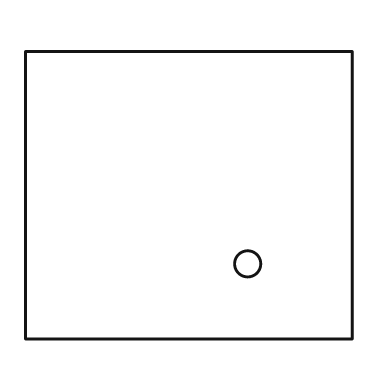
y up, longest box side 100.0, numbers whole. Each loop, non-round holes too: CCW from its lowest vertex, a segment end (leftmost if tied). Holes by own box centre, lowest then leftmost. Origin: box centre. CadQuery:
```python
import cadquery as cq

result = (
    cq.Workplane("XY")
    .moveTo(-50.0, -44.0)
    .lineTo(50.0, -44.0)
    .lineTo(50.0, 44.0)
    .lineTo(-50.0, 44.0)
    .close()
    .moveTo(18.0, -21.0)
    .circle(4.0)
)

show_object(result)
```